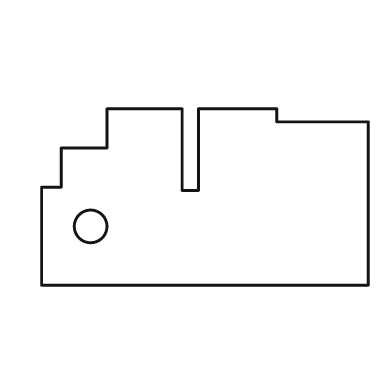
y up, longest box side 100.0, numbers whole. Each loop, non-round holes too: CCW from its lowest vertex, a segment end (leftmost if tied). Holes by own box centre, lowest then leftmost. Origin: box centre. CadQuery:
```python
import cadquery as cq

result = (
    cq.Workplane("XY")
    .moveTo(-50.0, -27.0)
    .lineTo(50.0, -27.0)
    .lineTo(50.0, 23.0)
    .lineTo(22.0, 23.0)
    .lineTo(22.0, 27.0)
    .lineTo(-2.0, 27.0)
    .lineTo(-2.0, 2.0)
    .lineTo(-7.0, 2.0)
    .lineTo(-7.0, 27.0)
    .lineTo(-30.0, 27.0)
    .lineTo(-30.0, 15.0)
    .lineTo(-44.0, 15.0)
    .lineTo(-44.0, 3.0)
    .lineTo(-50.0, 3.0)
    .close()
    .moveTo(-35.0, -9.0)
    .circle(5.0)
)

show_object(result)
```